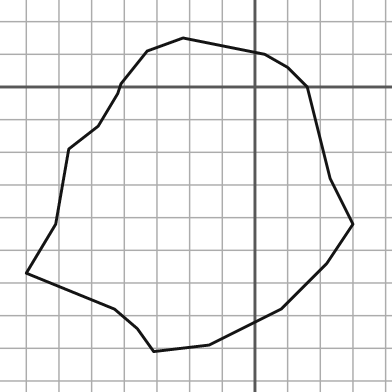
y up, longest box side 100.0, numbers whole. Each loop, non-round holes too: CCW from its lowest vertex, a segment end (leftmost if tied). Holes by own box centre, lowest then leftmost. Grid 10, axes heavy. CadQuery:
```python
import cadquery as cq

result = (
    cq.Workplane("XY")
    .moveTo(-31.0, -81.0)
    .lineTo(-14.0, -79.0)
    .lineTo(8.0, -68.0)
    .lineTo(22.0, -54.0)
    .lineTo(30.0, -42.0)
    .lineTo(23.0, -28.0)
    .lineTo(16.0, 0.0)
    .lineTo(10.0, 6.0)
    .lineTo(3.0, 10.0)
    .lineTo(-22.0, 15.0)
    .lineTo(-33.0, 11.0)
    .lineTo(-41.0, 1.0)
    .lineTo(-42.0, -2.0)
    .lineTo(-48.0, -12.0)
    .lineTo(-57.0, -19.0)
    .lineTo(-61.0, -42.0)
    .lineTo(-70.0, -57.0)
    .lineTo(-43.0, -68.0)
    .lineTo(-36.0, -74.0)
    .close()
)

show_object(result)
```